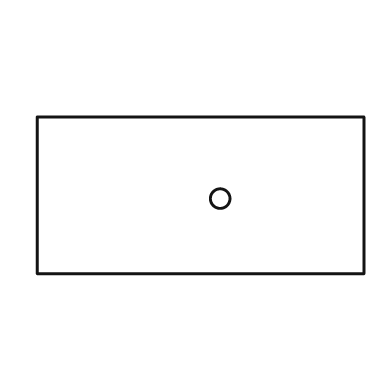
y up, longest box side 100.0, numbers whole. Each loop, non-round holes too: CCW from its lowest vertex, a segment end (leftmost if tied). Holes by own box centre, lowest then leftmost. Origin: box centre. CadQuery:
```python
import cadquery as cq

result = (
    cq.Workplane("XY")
    .moveTo(-50.0, -24.0)
    .lineTo(50.0, -24.0)
    .lineTo(50.0, 24.0)
    .lineTo(-50.0, 24.0)
    .close()
    .moveTo(6.0, -1.0)
    .circle(3.0)
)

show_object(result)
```